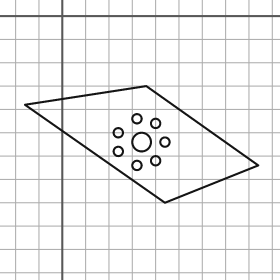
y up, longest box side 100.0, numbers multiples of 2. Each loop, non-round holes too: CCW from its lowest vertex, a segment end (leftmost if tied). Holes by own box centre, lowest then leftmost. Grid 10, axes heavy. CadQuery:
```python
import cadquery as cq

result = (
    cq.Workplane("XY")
    .moveTo(44.0, -80.0)
    .lineTo(84.0, -64.0)
    .lineTo(36.0, -30.0)
    .lineTo(-16.0, -38.0)
    .close()
    .moveTo(32.0, -64.0)
    .circle(2.0)
    .moveTo(40.0, -62.0)
    .circle(2.0)
    .moveTo(24.0, -58.0)
    .circle(2.0)
    .moveTo(34.0, -54.0)
    .circle(4.0)
    .moveTo(44.0, -54.0)
    .circle(2.0)
    .moveTo(24.0, -50.0)
    .circle(2.0)
    .moveTo(40.0, -46.0)
    .circle(2.0)
    .moveTo(32.0, -44.0)
    .circle(2.0)
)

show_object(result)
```